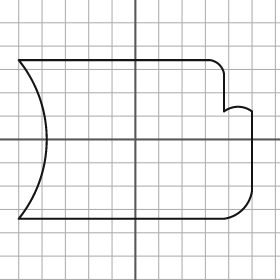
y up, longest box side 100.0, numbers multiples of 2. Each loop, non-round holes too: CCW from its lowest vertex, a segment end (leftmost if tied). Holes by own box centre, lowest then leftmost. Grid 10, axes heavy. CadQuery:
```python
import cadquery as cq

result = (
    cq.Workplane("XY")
    .moveTo(-50.0, -34.0)
    .lineTo(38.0, -34.0)
    .threePointArc((46.0, -30.0), (50.0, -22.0))
    .lineTo(50.0, 12.0)
    .threePointArc((44.0, 14.0), (38.0, 12.0))
    .lineTo(38.0, 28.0)
    .threePointArc((36.0, 32.0), (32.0, 34.0))
    .lineTo(-50.0, 34.0)
    .threePointArc((-38.0, 0.0), (-50.0, -34.0))
    .close()
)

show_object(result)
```